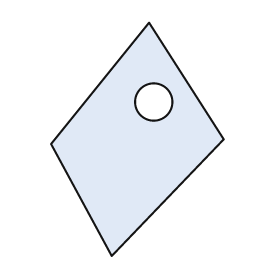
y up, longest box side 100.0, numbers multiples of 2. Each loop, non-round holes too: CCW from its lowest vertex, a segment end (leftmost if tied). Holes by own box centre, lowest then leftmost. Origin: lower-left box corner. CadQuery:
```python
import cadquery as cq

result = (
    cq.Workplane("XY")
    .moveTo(26.0, 0.0)
    .lineTo(74.0, 50.0)
    .lineTo(42.0, 100.0)
    .lineTo(0.0, 48.0)
    .close()
    .moveTo(44.0, 66.0)
    .circle(8.0)
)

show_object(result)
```